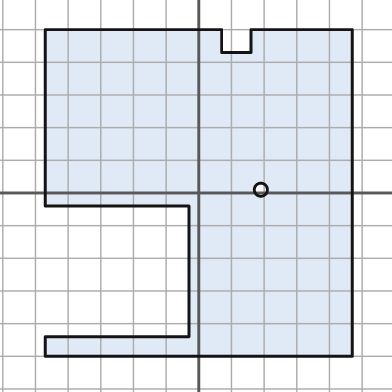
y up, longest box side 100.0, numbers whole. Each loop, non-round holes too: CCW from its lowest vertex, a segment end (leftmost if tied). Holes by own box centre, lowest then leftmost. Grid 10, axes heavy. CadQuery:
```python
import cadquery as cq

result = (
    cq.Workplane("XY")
    .moveTo(-47.0, -50.0)
    .lineTo(47.0, -50.0)
    .lineTo(47.0, 50.0)
    .lineTo(16.0, 50.0)
    .lineTo(16.0, 43.0)
    .lineTo(7.0, 43.0)
    .lineTo(7.0, 50.0)
    .lineTo(-47.0, 50.0)
    .lineTo(-47.0, -4.0)
    .lineTo(-3.0, -4.0)
    .lineTo(-3.0, -44.0)
    .lineTo(-47.0, -44.0)
    .close()
    .moveTo(19.0, 1.0)
    .circle(2.0)
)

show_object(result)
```